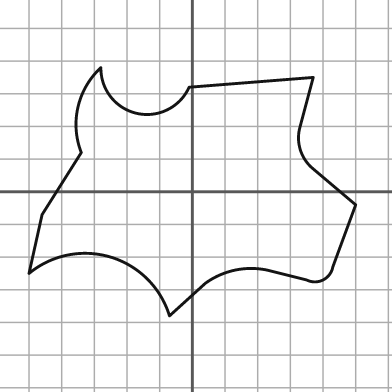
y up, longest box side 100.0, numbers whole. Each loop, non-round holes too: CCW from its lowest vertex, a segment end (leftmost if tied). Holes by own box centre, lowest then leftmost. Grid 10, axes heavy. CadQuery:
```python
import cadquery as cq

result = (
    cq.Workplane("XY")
    .moveTo(-7.0, -38.0)
    .lineTo(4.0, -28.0)
    .threePointArc((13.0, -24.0), (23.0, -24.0))
    .lineTo(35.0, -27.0)
    .threePointArc((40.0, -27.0), (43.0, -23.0))
    .lineTo(50.0, -4.0)
    .lineTo(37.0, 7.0)
    .threePointArc((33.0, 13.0), (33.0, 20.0))
    .lineTo(37.0, 35.0)
    .lineTo(-1.0, 32.0)
    .threePointArc((-17.0, 24.0), (-28.0, 38.0))
    .threePointArc((-35.0, 26.0), (-34.0, 12.0))
    .lineTo(-46.0, -7.0)
    .lineTo(-50.0, -25.0)
    .threePointArc((-25.0, -20.0), (-7.0, -38.0))
    .close()
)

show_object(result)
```